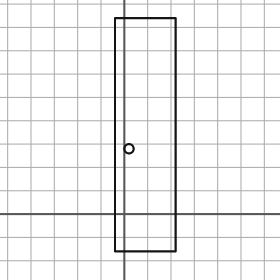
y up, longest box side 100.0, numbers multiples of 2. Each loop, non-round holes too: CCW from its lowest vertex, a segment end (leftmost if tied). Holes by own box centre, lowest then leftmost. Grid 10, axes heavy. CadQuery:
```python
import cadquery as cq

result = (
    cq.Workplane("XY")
    .moveTo(-4.0, -16.0)
    .lineTo(22.0, -16.0)
    .lineTo(22.0, 84.0)
    .lineTo(-4.0, 84.0)
    .close()
    .moveTo(2.0, 28.0)
    .circle(2.0)
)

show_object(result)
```